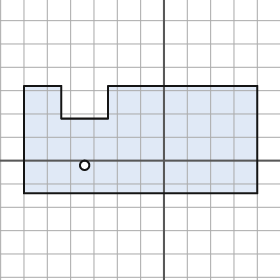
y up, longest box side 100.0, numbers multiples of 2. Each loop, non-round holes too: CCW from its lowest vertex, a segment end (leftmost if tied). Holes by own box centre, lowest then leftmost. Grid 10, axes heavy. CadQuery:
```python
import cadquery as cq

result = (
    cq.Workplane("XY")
    .moveTo(-60.0, -14.0)
    .lineTo(40.0, -14.0)
    .lineTo(40.0, 32.0)
    .lineTo(-24.0, 32.0)
    .lineTo(-24.0, 18.0)
    .lineTo(-44.0, 18.0)
    .lineTo(-44.0, 32.0)
    .lineTo(-60.0, 32.0)
    .close()
    .moveTo(-34.0, -2.0)
    .circle(2.0)
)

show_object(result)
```